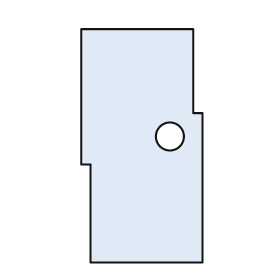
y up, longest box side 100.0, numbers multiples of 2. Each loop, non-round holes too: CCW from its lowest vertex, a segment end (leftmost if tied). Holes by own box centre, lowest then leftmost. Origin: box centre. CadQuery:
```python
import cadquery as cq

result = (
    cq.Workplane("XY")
    .moveTo(-22.0, -50.0)
    .lineTo(26.0, -50.0)
    .lineTo(26.0, 14.0)
    .lineTo(22.0, 14.0)
    .lineTo(22.0, 50.0)
    .lineTo(-26.0, 50.0)
    .lineTo(-26.0, -8.0)
    .lineTo(-22.0, -8.0)
    .close()
    .moveTo(12.0, 4.0)
    .circle(6.0)
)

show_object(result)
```